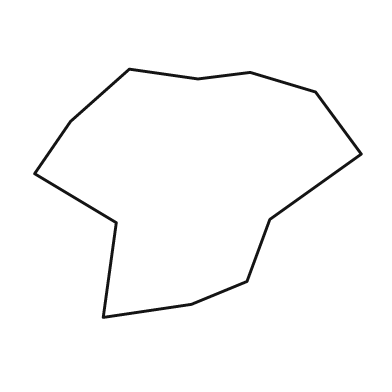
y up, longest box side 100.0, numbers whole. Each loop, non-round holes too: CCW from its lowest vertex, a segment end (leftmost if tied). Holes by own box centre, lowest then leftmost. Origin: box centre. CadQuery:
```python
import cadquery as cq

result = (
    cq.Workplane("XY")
    .moveTo(-29.0, -38.0)
    .lineTo(-2.0, -34.0)
    .lineTo(15.0, -27.0)
    .lineTo(22.0, -8.0)
    .lineTo(50.0, 12.0)
    .lineTo(36.0, 31.0)
    .lineTo(16.0, 37.0)
    .lineTo(0.0, 35.0)
    .lineTo(-21.0, 38.0)
    .lineTo(-39.0, 22.0)
    .lineTo(-50.0, 6.0)
    .lineTo(-25.0, -9.0)
    .close()
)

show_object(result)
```